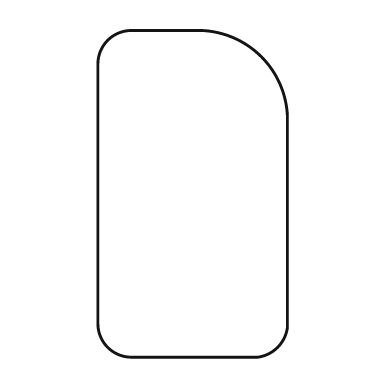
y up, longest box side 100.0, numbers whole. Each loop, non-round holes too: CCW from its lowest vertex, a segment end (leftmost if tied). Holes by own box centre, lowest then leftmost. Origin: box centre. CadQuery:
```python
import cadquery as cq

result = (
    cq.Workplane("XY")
    .moveTo(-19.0, -50.0)
    .lineTo(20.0, -50.0)
    .threePointArc((26.0, -47.0), (29.0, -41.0))
    .lineTo(29.0, 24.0)
    .threePointArc((21.0, 42.0), (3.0, 50.0))
    .lineTo(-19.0, 50.0)
    .threePointArc((-26.0, 47.0), (-29.0, 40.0))
    .lineTo(-29.0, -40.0)
    .threePointArc((-26.0, -47.0), (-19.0, -50.0))
    .close()
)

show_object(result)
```